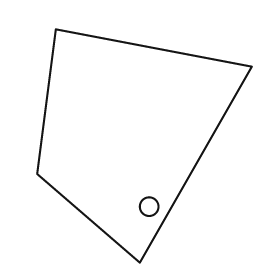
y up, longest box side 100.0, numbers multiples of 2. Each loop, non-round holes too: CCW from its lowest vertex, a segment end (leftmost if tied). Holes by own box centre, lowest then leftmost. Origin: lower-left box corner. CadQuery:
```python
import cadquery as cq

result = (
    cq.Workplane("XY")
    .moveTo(44.0, 0.0)
    .lineTo(92.0, 84.0)
    .lineTo(8.0, 100.0)
    .lineTo(0.0, 38.0)
    .close()
    .moveTo(48.0, 24.0)
    .circle(4.0)
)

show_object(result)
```